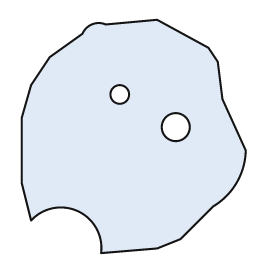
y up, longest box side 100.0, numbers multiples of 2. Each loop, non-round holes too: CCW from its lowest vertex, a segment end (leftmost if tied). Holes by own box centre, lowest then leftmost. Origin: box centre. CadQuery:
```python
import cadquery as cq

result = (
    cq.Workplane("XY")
    .moveTo(-14.0, -50.0)
    .lineTo(10.0, -48.0)
    .lineTo(20.0, -44.0)
    .lineTo(34.0, -30.0)
    .threePointArc((44.0, -20.0), (48.0, -6.0))
    .lineTo(38.0, 16.0)
    .lineTo(36.0, 32.0)
    .lineTo(32.0, 38.0)
    .lineTo(10.0, 50.0)
    .lineTo(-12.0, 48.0)
    .threePointArc((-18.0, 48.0), (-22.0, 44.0))
    .lineTo(-36.0, 34.0)
    .lineTo(-44.0, 22.0)
    .lineTo(-48.0, 8.0)
    .lineTo(-48.0, -20.0)
    .lineTo(-44.0, -36.0)
    .threePointArc((-24.0, -32.0), (-14.0, -50.0))
    .close()
    .moveTo(18.0, 4.0)
    .circle(6.0)
    .moveTo(-6.0, 18.0)
    .circle(4.0)
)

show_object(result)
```